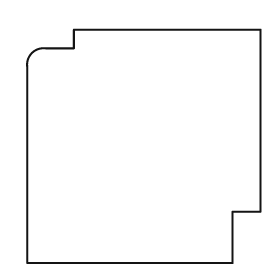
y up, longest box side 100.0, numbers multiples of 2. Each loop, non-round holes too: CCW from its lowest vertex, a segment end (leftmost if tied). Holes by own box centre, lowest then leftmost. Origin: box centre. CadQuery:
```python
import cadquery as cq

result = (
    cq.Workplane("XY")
    .moveTo(-50.0, -50.0)
    .lineTo(38.0, -50.0)
    .lineTo(38.0, -28.0)
    .lineTo(50.0, -28.0)
    .lineTo(50.0, 50.0)
    .lineTo(-30.0, 50.0)
    .lineTo(-30.0, 42.0)
    .lineTo(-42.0, 42.0)
    .threePointArc((-48.0, 40.0), (-50.0, 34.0))
    .close()
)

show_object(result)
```